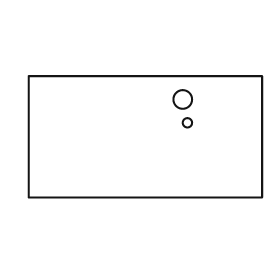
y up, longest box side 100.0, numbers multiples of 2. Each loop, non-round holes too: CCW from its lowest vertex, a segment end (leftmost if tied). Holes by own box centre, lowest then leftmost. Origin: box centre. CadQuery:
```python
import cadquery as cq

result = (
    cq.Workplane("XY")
    .moveTo(-50.0, -26.0)
    .lineTo(50.0, -26.0)
    .lineTo(50.0, 26.0)
    .lineTo(-50.0, 26.0)
    .close()
    .moveTo(18.0, 6.0)
    .circle(2.0)
    .moveTo(16.0, 16.0)
    .circle(4.0)
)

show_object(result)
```